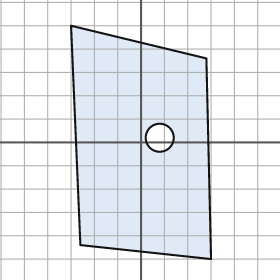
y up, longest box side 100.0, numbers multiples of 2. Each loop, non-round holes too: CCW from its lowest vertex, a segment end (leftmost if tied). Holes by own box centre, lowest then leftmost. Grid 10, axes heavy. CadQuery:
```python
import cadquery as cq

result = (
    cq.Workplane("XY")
    .moveTo(30.0, -50.0)
    .lineTo(28.0, 36.0)
    .lineTo(-30.0, 50.0)
    .lineTo(-26.0, -44.0)
    .close()
    .moveTo(8.0, 2.0)
    .circle(6.0)
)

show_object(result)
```